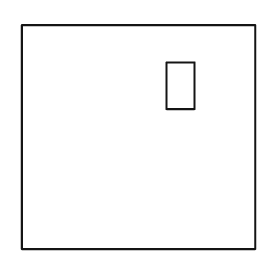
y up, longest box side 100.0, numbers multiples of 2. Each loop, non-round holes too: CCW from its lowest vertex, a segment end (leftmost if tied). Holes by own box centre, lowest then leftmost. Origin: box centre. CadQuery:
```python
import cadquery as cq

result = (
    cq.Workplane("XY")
    .moveTo(-50.0, -48.0)
    .lineTo(50.0, -48.0)
    .lineTo(50.0, 48.0)
    .lineTo(-50.0, 48.0)
    .close()
    .moveTo(12.0, 12.0)
    .lineTo(24.0, 12.0)
    .lineTo(24.0, 32.0)
    .lineTo(12.0, 32.0)
    .close()
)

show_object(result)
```